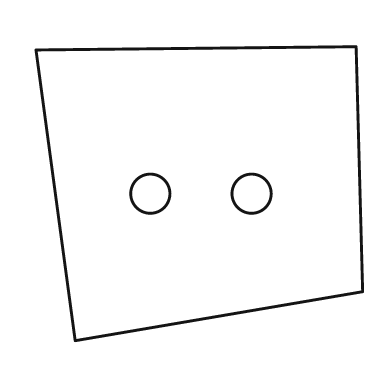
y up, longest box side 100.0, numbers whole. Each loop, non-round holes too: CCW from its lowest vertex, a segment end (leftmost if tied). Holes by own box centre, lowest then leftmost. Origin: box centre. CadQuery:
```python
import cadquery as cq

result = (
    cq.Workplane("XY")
    .moveTo(-38.0, -45.0)
    .lineTo(50.0, -30.0)
    .lineTo(48.0, 45.0)
    .lineTo(-50.0, 44.0)
    .close()
    .moveTo(-15.0, 0.0)
    .circle(6.0)
    .moveTo(16.0, 0.0)
    .circle(6.0)
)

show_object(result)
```